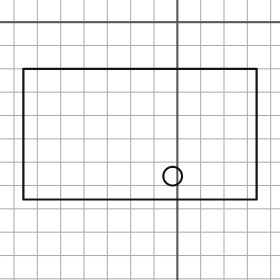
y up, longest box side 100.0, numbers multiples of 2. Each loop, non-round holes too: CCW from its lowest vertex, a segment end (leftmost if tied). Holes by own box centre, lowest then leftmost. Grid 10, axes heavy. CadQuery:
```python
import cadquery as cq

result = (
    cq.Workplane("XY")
    .moveTo(-66.0, -76.0)
    .lineTo(34.0, -76.0)
    .lineTo(34.0, -20.0)
    .lineTo(-66.0, -20.0)
    .close()
    .moveTo(-2.0, -66.0)
    .circle(4.0)
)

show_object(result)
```